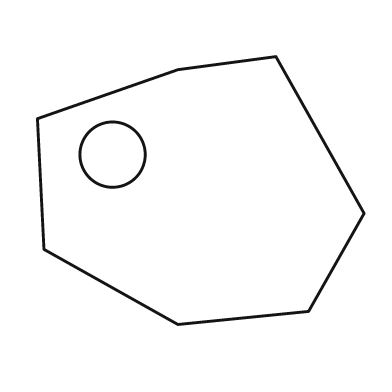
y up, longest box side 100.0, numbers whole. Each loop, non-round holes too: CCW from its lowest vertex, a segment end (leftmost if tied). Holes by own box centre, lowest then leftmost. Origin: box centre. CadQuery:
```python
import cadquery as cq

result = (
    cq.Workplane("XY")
    .moveTo(-7.0, -41.0)
    .lineTo(33.0, -37.0)
    .lineTo(50.0, -7.0)
    .lineTo(23.0, 41.0)
    .lineTo(-7.0, 37.0)
    .lineTo(-50.0, 22.0)
    .lineTo(-48.0, -18.0)
    .close()
    .moveTo(-27.0, 11.0)
    .circle(10.0)
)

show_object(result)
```